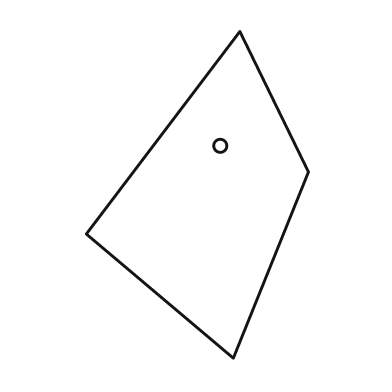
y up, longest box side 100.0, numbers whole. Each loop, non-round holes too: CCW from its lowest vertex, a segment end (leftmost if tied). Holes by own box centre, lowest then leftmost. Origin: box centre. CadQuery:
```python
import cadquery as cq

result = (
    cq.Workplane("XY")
    .moveTo(11.0, -50.0)
    .lineTo(34.0, 7.0)
    .lineTo(13.0, 50.0)
    .lineTo(-34.0, -12.0)
    .close()
    .moveTo(7.0, 15.0)
    .circle(2.0)
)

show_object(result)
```